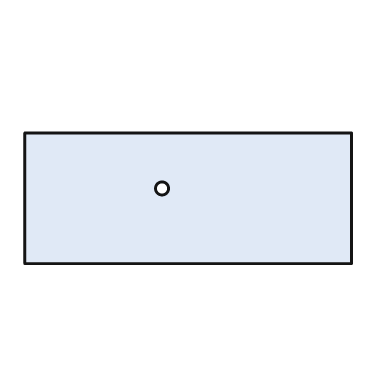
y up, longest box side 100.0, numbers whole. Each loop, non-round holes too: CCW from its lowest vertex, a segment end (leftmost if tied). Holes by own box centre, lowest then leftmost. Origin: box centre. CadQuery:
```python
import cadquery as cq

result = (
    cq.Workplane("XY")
    .moveTo(-50.0, -20.0)
    .lineTo(50.0, -20.0)
    .lineTo(50.0, 20.0)
    .lineTo(-50.0, 20.0)
    .close()
    .moveTo(-8.0, 3.0)
    .circle(2.0)
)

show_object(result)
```